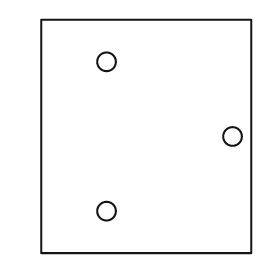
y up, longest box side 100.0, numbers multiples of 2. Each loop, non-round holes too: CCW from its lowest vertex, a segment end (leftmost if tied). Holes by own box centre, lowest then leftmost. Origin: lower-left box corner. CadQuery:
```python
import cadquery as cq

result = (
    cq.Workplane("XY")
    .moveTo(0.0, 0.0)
    .lineTo(90.0, 0.0)
    .lineTo(90.0, 100.0)
    .lineTo(0.0, 100.0)
    .close()
    .moveTo(28.0, 18.0)
    .circle(4.0)
    .moveTo(82.0, 50.0)
    .circle(4.0)
    .moveTo(28.0, 82.0)
    .circle(4.0)
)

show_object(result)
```